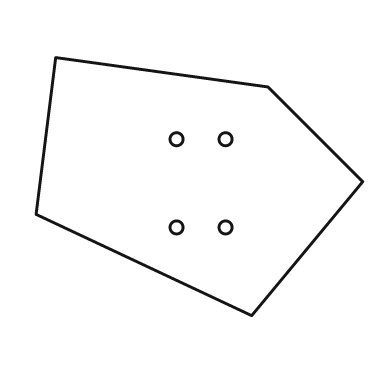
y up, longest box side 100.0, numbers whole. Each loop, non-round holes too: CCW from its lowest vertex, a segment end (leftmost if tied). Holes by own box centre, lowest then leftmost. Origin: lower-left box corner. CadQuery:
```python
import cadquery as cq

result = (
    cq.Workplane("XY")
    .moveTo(66.0, 0.0)
    .lineTo(100.0, 41.0)
    .lineTo(71.0, 70.0)
    .lineTo(6.0, 79.0)
    .lineTo(0.0, 31.0)
    .close()
    .moveTo(43.0, 27.0)
    .circle(2.0)
    .moveTo(58.0, 27.0)
    .circle(2.0)
    .moveTo(43.0, 54.0)
    .circle(2.0)
    .moveTo(58.0, 54.0)
    .circle(2.0)
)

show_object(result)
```